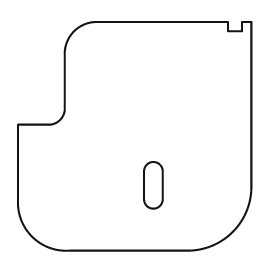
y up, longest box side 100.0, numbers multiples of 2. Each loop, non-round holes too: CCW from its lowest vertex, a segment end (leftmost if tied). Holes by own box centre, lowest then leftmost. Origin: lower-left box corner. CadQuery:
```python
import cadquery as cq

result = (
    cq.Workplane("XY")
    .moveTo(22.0, 0.0)
    .lineTo(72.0, 0.0)
    .threePointArc((92.0, 8.0), (100.0, 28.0))
    .lineTo(100.0, 98.0)
    .lineTo(96.0, 98.0)
    .lineTo(96.0, 94.0)
    .lineTo(90.0, 94.0)
    .lineTo(90.0, 98.0)
    .lineTo(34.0, 98.0)
    .threePointArc((24.0, 94.0), (20.0, 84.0))
    .lineTo(20.0, 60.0)
    .threePointArc((18.0, 56.0), (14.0, 54.0))
    .lineTo(0.0, 54.0)
    .lineTo(0.0, 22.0)
    .threePointArc((6.0, 6.0), (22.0, 0.0))
    .close()
    .moveTo(54.0, 22.0)
    .threePointArc((58.0, 18.0), (62.0, 22.0))
    .lineTo(62.0, 34.0)
    .threePointArc((58.0, 38.0), (54.0, 34.0))
    .close()
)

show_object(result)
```